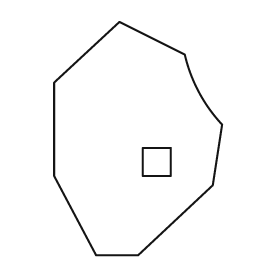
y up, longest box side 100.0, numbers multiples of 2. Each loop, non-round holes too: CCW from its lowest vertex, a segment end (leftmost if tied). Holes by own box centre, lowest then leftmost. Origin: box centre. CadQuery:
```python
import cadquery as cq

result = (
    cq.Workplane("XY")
    .moveTo(-18.0, -50.0)
    .lineTo(0.0, -50.0)
    .lineTo(32.0, -20.0)
    .lineTo(36.0, 6.0)
    .threePointArc((26.0, 20.0), (20.0, 36.0))
    .lineTo(-8.0, 50.0)
    .lineTo(-36.0, 24.0)
    .lineTo(-36.0, -16.0)
    .close()
    .moveTo(2.0, -16.0)
    .lineTo(14.0, -16.0)
    .lineTo(14.0, -4.0)
    .lineTo(2.0, -4.0)
    .close()
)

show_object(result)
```